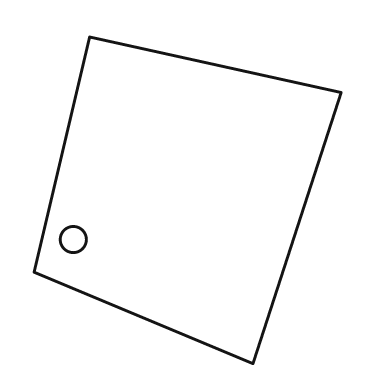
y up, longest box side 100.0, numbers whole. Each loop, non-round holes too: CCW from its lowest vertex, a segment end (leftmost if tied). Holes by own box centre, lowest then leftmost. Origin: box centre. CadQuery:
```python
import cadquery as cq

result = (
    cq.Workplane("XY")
    .moveTo(20.0, -50.0)
    .lineTo(47.0, 33.0)
    .lineTo(-30.0, 50.0)
    .lineTo(-47.0, -22.0)
    .close()
    .moveTo(-35.0, -12.0)
    .circle(4.0)
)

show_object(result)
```